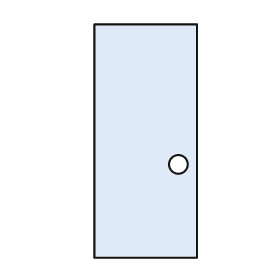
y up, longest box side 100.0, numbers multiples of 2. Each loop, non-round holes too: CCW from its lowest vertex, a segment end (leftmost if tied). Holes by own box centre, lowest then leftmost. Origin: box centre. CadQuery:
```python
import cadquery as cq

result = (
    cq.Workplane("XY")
    .moveTo(-22.0, -50.0)
    .lineTo(22.0, -50.0)
    .lineTo(22.0, 50.0)
    .lineTo(-22.0, 50.0)
    .close()
    .moveTo(14.0, -10.0)
    .circle(4.0)
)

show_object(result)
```